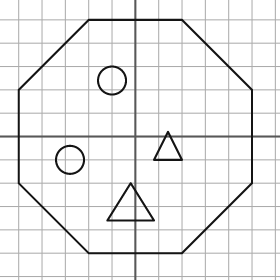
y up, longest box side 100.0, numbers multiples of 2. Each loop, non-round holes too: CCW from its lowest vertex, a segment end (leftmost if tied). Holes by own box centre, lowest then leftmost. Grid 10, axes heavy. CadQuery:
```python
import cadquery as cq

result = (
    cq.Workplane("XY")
    .moveTo(-20.0, -50.0)
    .lineTo(20.0, -50.0)
    .lineTo(50.0, -20.0)
    .lineTo(50.0, 20.0)
    .lineTo(20.0, 50.0)
    .lineTo(-20.0, 50.0)
    .lineTo(-50.0, 20.0)
    .lineTo(-50.0, -20.0)
    .close()
    .moveTo(-12.0, -36.0)
    .lineTo(8.0, -36.0)
    .lineTo(-2.0, -20.0)
    .close()
    .moveTo(-28.0, -10.0)
    .circle(6.0)
    .moveTo(8.0, -10.0)
    .lineTo(20.0, -10.0)
    .lineTo(14.0, 2.0)
    .close()
    .moveTo(-10.0, 24.0)
    .circle(6.0)
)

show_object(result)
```